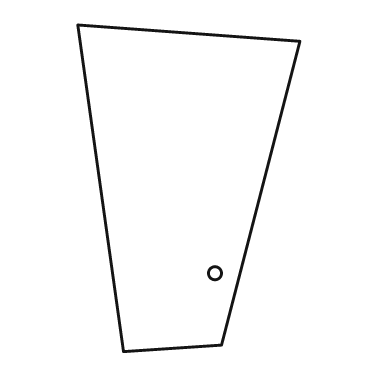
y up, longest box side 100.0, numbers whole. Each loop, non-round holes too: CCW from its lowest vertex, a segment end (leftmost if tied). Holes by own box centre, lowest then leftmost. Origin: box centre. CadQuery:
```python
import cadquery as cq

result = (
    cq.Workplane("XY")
    .moveTo(-20.0, -50.0)
    .lineTo(10.0, -48.0)
    .lineTo(34.0, 45.0)
    .lineTo(-34.0, 50.0)
    .close()
    .moveTo(8.0, -26.0)
    .circle(2.0)
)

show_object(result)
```